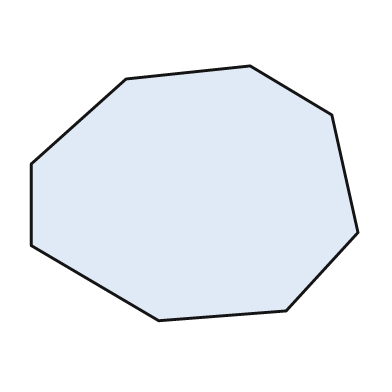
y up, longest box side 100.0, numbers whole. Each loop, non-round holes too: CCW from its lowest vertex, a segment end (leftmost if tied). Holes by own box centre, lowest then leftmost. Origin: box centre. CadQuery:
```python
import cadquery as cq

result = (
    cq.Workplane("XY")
    .moveTo(-11.0, -39.0)
    .lineTo(28.0, -36.0)
    .lineTo(50.0, -12.0)
    .lineTo(42.0, 24.0)
    .lineTo(17.0, 39.0)
    .lineTo(-21.0, 35.0)
    .lineTo(-50.0, 9.0)
    .lineTo(-50.0, -16.0)
    .close()
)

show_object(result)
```